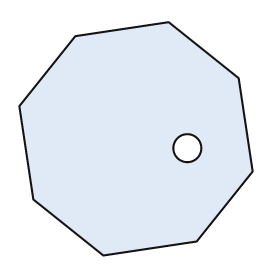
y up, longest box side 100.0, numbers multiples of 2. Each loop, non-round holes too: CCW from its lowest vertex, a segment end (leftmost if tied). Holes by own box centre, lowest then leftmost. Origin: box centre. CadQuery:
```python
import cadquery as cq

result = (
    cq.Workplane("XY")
    .moveTo(-14.0, -50.0)
    .lineTo(26.0, -44.0)
    .lineTo(50.0, -14.0)
    .lineTo(44.0, 26.0)
    .lineTo(14.0, 50.0)
    .lineTo(-26.0, 44.0)
    .lineTo(-50.0, 14.0)
    .lineTo(-44.0, -26.0)
    .close()
    .moveTo(22.0, -4.0)
    .circle(6.0)
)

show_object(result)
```